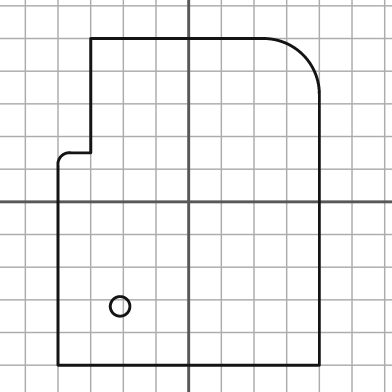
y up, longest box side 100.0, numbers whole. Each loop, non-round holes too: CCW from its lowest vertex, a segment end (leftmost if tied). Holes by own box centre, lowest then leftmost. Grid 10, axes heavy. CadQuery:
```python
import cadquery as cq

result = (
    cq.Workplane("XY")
    .moveTo(-40.0, -50.0)
    .lineTo(40.0, -50.0)
    .lineTo(40.0, 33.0)
    .threePointArc((35.0, 45.0), (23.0, 50.0))
    .lineTo(-30.0, 50.0)
    .lineTo(-30.0, 15.0)
    .lineTo(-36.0, 15.0)
    .threePointArc((-39.0, 14.0), (-40.0, 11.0))
    .close()
    .moveTo(-21.0, -32.0)
    .circle(3.0)
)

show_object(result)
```